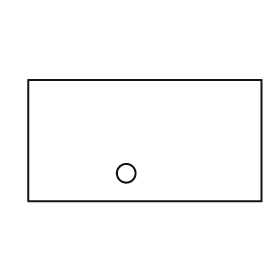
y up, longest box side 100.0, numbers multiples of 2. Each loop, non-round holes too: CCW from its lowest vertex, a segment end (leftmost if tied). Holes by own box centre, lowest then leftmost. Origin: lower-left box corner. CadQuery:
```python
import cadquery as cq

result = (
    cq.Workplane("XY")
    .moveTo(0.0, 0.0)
    .lineTo(100.0, 0.0)
    .lineTo(100.0, 52.0)
    .lineTo(0.0, 52.0)
    .close()
    .moveTo(42.0, 12.0)
    .circle(4.0)
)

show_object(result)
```